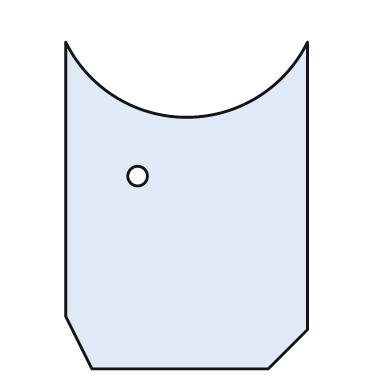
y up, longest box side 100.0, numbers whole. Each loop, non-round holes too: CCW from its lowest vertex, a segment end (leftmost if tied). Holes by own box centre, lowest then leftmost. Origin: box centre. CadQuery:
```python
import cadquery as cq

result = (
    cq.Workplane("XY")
    .moveTo(-29.0, -50.0)
    .lineTo(25.0, -50.0)
    .lineTo(37.0, -38.0)
    .lineTo(37.0, 50.0)
    .threePointArc((0.0, 27.0), (-37.0, 50.0))
    .lineTo(-37.0, -34.0)
    .close()
    .moveTo(-15.0, 9.0)
    .circle(3.0)
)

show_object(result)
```